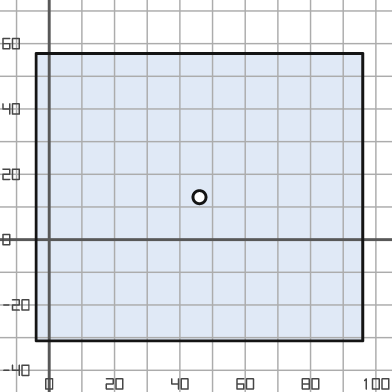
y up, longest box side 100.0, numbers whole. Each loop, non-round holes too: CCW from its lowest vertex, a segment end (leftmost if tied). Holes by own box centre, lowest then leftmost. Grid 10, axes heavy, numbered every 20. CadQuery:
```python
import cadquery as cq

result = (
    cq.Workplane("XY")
    .moveTo(-4.0, -31.0)
    .lineTo(96.0, -31.0)
    .lineTo(96.0, 57.0)
    .lineTo(-4.0, 57.0)
    .close()
    .moveTo(46.0, 13.0)
    .circle(2.0)
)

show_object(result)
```